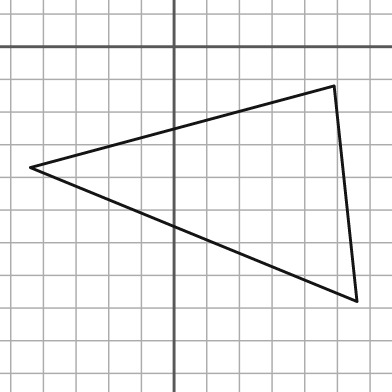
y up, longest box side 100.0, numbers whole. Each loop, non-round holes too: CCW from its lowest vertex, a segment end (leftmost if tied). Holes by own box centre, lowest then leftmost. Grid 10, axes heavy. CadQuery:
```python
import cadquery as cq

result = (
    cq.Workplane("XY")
    .moveTo(56.0, -78.0)
    .lineTo(49.0, -12.0)
    .lineTo(-44.0, -37.0)
    .close()
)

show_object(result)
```